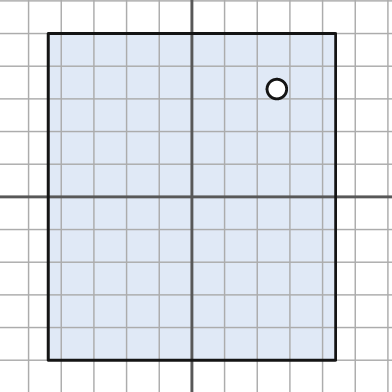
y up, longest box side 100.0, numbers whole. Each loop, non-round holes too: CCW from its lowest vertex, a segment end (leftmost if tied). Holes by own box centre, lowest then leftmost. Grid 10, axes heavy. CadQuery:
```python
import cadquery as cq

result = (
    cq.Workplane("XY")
    .moveTo(-44.0, -50.0)
    .lineTo(44.0, -50.0)
    .lineTo(44.0, 50.0)
    .lineTo(-44.0, 50.0)
    .close()
    .moveTo(26.0, 33.0)
    .circle(3.0)
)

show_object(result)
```